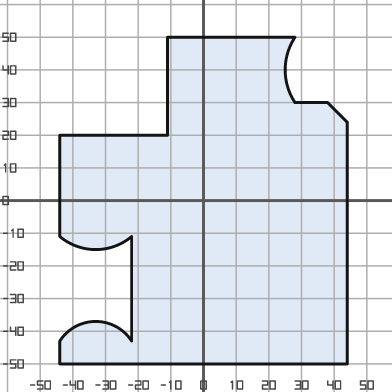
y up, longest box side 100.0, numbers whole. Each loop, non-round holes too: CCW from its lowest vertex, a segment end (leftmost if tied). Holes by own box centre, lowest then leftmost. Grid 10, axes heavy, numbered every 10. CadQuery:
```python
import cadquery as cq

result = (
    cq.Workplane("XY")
    .moveTo(-44.0, -50.0)
    .lineTo(44.0, -50.0)
    .lineTo(44.0, 24.0)
    .lineTo(38.0, 30.0)
    .lineTo(28.0, 30.0)
    .threePointArc((25.0, 40.0), (28.0, 50.0))
    .lineTo(-11.0, 50.0)
    .lineTo(-11.0, 20.0)
    .lineTo(-44.0, 20.0)
    .lineTo(-44.0, -11.0)
    .threePointArc((-33.0, -15.0), (-22.0, -11.0))
    .lineTo(-22.0, -43.0)
    .threePointArc((-33.0, -37.0), (-44.0, -43.0))
    .close()
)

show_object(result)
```